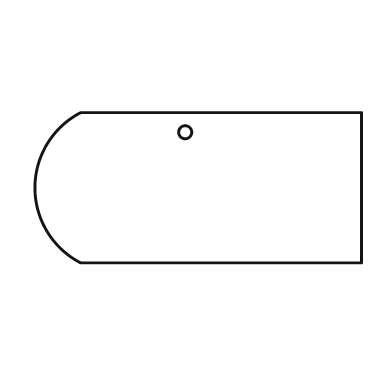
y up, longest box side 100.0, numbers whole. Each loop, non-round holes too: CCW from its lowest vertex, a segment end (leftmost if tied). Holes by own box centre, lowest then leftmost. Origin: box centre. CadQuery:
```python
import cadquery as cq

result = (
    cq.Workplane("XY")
    .moveTo(-36.0, -23.0)
    .lineTo(50.0, -23.0)
    .lineTo(50.0, 23.0)
    .lineTo(-36.0, 23.0)
    .threePointArc((-50.0, 0.0), (-36.0, -23.0))
    .close()
    .moveTo(-4.0, 17.0)
    .circle(2.0)
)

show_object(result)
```